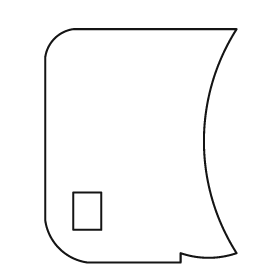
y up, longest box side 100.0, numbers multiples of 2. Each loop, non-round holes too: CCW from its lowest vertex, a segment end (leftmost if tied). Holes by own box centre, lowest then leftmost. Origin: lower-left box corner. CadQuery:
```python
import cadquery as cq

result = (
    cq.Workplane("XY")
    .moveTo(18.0, 0.0)
    .lineTo(58.0, 0.0)
    .lineTo(58.0, 4.0)
    .threePointArc((70.0, 2.0), (82.0, 4.0))
    .threePointArc((68.0, 52.0), (82.0, 100.0))
    .lineTo(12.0, 100.0)
    .threePointArc((4.0, 96.0), (0.0, 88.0))
    .lineTo(0.0, 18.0)
    .threePointArc((6.0, 6.0), (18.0, 0.0))
    .close()
    .moveTo(12.0, 14.0)
    .lineTo(24.0, 14.0)
    .lineTo(24.0, 30.0)
    .lineTo(12.0, 30.0)
    .close()
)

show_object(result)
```